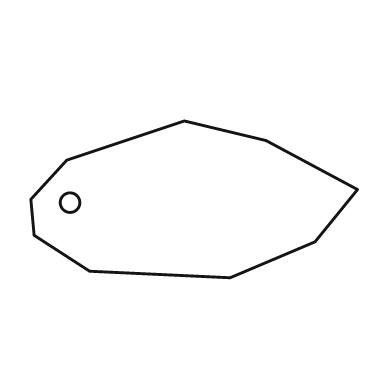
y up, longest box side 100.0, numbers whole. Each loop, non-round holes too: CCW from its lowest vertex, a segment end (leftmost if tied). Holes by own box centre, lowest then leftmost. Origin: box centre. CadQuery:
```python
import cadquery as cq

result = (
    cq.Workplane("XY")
    .moveTo(11.0, -24.0)
    .lineTo(37.0, -13.0)
    .lineTo(50.0, 3.0)
    .lineTo(22.0, 18.0)
    .lineTo(-3.0, 24.0)
    .lineTo(-39.0, 12.0)
    .lineTo(-50.0, 0.0)
    .lineTo(-49.0, -11.0)
    .lineTo(-32.0, -22.0)
    .close()
    .moveTo(-38.0, -1.0)
    .circle(3.0)
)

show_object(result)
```